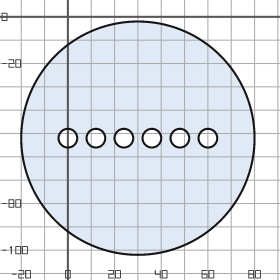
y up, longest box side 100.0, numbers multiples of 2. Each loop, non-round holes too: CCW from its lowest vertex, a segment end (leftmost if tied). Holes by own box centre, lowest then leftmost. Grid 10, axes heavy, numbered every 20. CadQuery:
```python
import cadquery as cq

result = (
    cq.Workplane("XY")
    .moveTo(30.0, -52.0)
    .circle(50.0)
    .moveTo(0.0, -52.0)
    .circle(4.0)
    .moveTo(12.0, -52.0)
    .circle(4.0)
    .moveTo(24.0, -52.0)
    .circle(4.0)
    .moveTo(36.0, -52.0)
    .circle(4.0)
    .moveTo(48.0, -52.0)
    .circle(4.0)
    .moveTo(60.0, -52.0)
    .circle(4.0)
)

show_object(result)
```